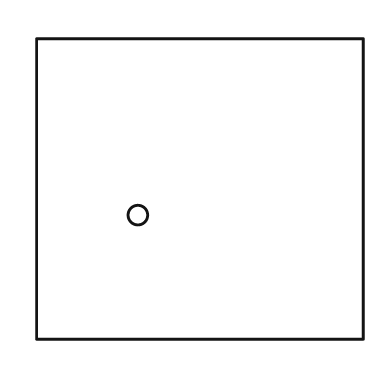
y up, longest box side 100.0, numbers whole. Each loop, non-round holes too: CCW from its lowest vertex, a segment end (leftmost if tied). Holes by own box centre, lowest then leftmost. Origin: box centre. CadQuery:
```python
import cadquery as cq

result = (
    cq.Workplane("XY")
    .moveTo(-50.0, -46.0)
    .lineTo(50.0, -46.0)
    .lineTo(50.0, 46.0)
    .lineTo(-50.0, 46.0)
    .close()
    .moveTo(-19.0, -8.0)
    .circle(3.0)
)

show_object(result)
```